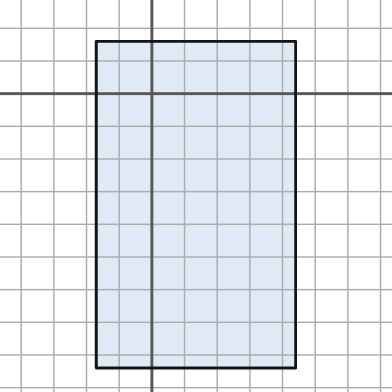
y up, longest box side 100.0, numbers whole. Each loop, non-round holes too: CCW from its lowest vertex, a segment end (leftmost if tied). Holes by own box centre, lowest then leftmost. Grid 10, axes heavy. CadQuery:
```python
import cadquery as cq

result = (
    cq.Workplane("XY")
    .moveTo(-17.0, -84.0)
    .lineTo(44.0, -84.0)
    .lineTo(44.0, 16.0)
    .lineTo(-17.0, 16.0)
    .close()
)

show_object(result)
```